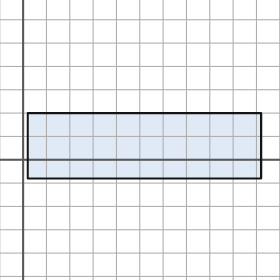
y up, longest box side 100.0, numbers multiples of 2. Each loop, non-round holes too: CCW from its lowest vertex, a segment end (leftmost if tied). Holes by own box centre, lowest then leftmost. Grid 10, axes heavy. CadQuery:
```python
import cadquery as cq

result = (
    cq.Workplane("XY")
    .moveTo(2.0, -8.0)
    .lineTo(102.0, -8.0)
    .lineTo(102.0, 20.0)
    .lineTo(2.0, 20.0)
    .close()
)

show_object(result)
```